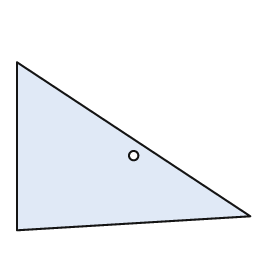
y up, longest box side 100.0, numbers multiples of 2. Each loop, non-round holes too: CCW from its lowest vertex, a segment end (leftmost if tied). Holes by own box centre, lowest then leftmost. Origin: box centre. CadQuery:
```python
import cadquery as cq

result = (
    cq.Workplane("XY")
    .moveTo(-50.0, -36.0)
    .lineTo(50.0, -30.0)
    .lineTo(-50.0, 36.0)
    .close()
    .moveTo(0.0, -4.0)
    .circle(2.0)
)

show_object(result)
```